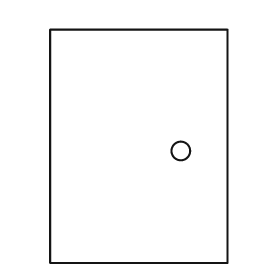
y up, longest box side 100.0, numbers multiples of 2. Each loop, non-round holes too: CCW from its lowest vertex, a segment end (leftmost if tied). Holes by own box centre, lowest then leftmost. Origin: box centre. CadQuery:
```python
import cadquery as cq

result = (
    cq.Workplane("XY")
    .moveTo(-38.0, -50.0)
    .lineTo(38.0, -50.0)
    .lineTo(38.0, 50.0)
    .lineTo(-38.0, 50.0)
    .close()
    .moveTo(18.0, -2.0)
    .circle(4.0)
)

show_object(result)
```